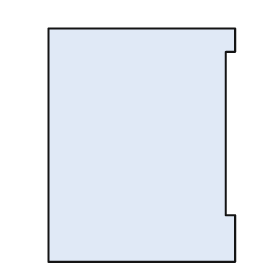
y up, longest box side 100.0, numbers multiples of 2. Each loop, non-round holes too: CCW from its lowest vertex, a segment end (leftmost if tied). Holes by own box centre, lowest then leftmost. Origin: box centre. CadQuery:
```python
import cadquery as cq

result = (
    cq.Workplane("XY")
    .moveTo(-40.0, -50.0)
    .lineTo(40.0, -50.0)
    .lineTo(40.0, -30.0)
    .lineTo(36.0, -30.0)
    .lineTo(36.0, 40.0)
    .lineTo(40.0, 40.0)
    .lineTo(40.0, 50.0)
    .lineTo(-40.0, 50.0)
    .close()
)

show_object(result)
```